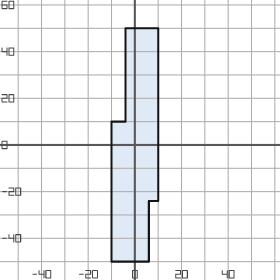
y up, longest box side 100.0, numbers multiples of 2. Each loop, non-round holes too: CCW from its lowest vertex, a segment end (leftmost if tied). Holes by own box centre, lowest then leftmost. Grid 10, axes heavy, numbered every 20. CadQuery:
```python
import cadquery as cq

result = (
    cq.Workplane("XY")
    .moveTo(-10.0, -50.0)
    .lineTo(6.0, -50.0)
    .lineTo(6.0, -24.0)
    .lineTo(10.0, -24.0)
    .lineTo(10.0, 50.0)
    .lineTo(-4.0, 50.0)
    .lineTo(-4.0, 10.0)
    .lineTo(-10.0, 10.0)
    .close()
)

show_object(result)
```